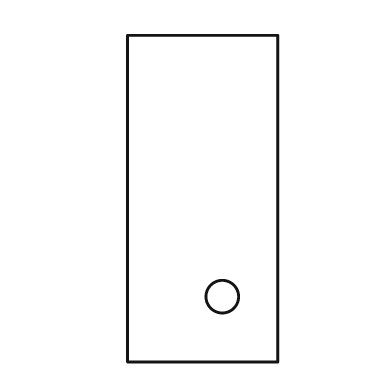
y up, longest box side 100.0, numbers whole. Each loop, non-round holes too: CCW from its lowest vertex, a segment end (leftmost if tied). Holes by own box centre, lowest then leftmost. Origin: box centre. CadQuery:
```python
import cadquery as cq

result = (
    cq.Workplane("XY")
    .moveTo(-23.0, -50.0)
    .lineTo(23.0, -50.0)
    .lineTo(23.0, 50.0)
    .lineTo(-23.0, 50.0)
    .close()
    .moveTo(6.0, -30.0)
    .circle(5.0)
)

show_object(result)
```